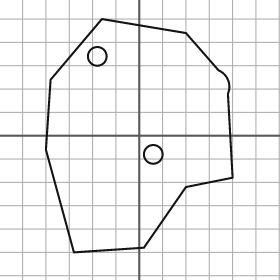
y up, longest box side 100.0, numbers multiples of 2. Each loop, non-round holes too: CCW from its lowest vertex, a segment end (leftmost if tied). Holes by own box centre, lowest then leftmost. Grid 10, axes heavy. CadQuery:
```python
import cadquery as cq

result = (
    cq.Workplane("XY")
    .moveTo(-28.0, -50.0)
    .lineTo(2.0, -48.0)
    .lineTo(20.0, -22.0)
    .lineTo(40.0, -18.0)
    .lineTo(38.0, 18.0)
    .threePointArc((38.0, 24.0), (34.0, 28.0))
    .lineTo(20.0, 44.0)
    .lineTo(-16.0, 50.0)
    .lineTo(-38.0, 24.0)
    .lineTo(-40.0, -6.0)
    .close()
    .moveTo(6.0, -8.0)
    .circle(4.0)
    .moveTo(-18.0, 34.0)
    .circle(4.0)
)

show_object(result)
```